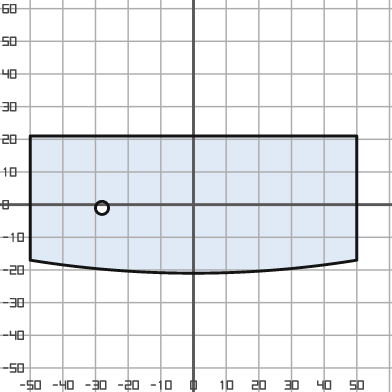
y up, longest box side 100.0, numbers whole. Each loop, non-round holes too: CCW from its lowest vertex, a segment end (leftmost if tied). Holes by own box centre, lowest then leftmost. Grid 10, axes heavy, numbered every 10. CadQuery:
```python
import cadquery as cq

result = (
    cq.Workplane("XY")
    .moveTo(-50.0, -17.0)
    .threePointArc((0.0, -21.0), (50.0, -17.0))
    .lineTo(50.0, 21.0)
    .lineTo(-50.0, 21.0)
    .close()
    .moveTo(-28.0, -1.0)
    .circle(2.0)
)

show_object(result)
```